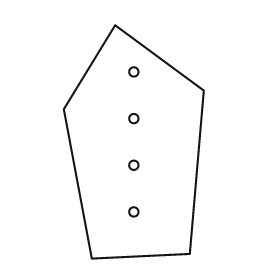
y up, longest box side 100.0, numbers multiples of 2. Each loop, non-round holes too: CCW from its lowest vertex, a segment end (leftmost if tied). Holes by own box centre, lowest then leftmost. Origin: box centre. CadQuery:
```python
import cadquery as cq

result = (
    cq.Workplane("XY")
    .moveTo(-18.0, -50.0)
    .lineTo(24.0, -48.0)
    .lineTo(30.0, 22.0)
    .lineTo(-8.0, 50.0)
    .lineTo(-30.0, 14.0)
    .close()
    .moveTo(0.0, -30.0)
    .circle(2.0)
    .moveTo(0.0, -10.0)
    .circle(2.0)
    .moveTo(0.0, 10.0)
    .circle(2.0)
    .moveTo(0.0, 30.0)
    .circle(2.0)
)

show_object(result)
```